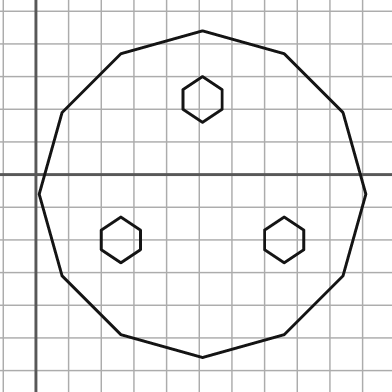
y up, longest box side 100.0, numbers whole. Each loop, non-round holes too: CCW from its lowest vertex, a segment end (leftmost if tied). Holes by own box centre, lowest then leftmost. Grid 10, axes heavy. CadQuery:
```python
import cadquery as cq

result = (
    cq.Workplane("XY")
    .moveTo(51.0, -56.0)
    .lineTo(76.0, -49.0)
    .lineTo(94.0, -31.0)
    .lineTo(101.0, -6.0)
    .lineTo(94.0, 19.0)
    .lineTo(76.0, 37.0)
    .lineTo(51.0, 44.0)
    .lineTo(26.0, 37.0)
    .lineTo(8.0, 19.0)
    .lineTo(1.0, -6.0)
    .lineTo(8.0, -31.0)
    .lineTo(26.0, -49.0)
    .close()
    .moveTo(26.0, -27.0)
    .lineTo(32.0, -23.0)
    .lineTo(32.0, -17.0)
    .lineTo(26.0, -13.0)
    .lineTo(20.0, -17.0)
    .lineTo(20.0, -23.0)
    .close()
    .moveTo(76.0, -27.0)
    .lineTo(82.0, -23.0)
    .lineTo(82.0, -17.0)
    .lineTo(76.0, -13.0)
    .lineTo(70.0, -17.0)
    .lineTo(70.0, -23.0)
    .close()
    .moveTo(51.0, 16.0)
    .lineTo(57.0, 20.0)
    .lineTo(57.0, 26.0)
    .lineTo(51.0, 30.0)
    .lineTo(45.0, 26.0)
    .lineTo(45.0, 20.0)
    .close()
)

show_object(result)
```